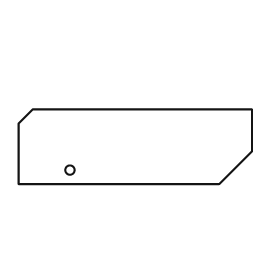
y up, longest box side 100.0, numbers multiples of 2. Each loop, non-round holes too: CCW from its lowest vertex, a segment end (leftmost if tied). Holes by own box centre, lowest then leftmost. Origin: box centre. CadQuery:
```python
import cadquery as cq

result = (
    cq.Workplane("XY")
    .moveTo(-50.0, -16.0)
    .lineTo(36.0, -16.0)
    .lineTo(50.0, -2.0)
    .lineTo(50.0, 16.0)
    .lineTo(-44.0, 16.0)
    .lineTo(-50.0, 10.0)
    .close()
    .moveTo(-28.0, -10.0)
    .circle(2.0)
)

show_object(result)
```